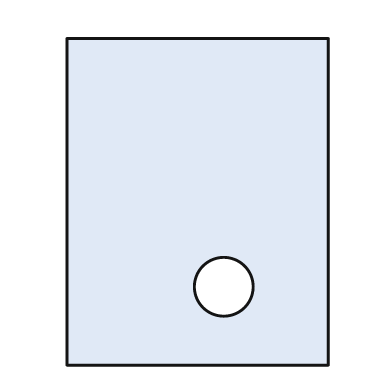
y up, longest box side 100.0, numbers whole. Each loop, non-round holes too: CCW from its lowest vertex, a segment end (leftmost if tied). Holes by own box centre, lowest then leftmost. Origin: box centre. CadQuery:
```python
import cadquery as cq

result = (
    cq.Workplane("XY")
    .moveTo(-40.0, -50.0)
    .lineTo(40.0, -50.0)
    .lineTo(40.0, 50.0)
    .lineTo(-40.0, 50.0)
    .close()
    .moveTo(8.0, -26.0)
    .circle(9.0)
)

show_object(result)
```